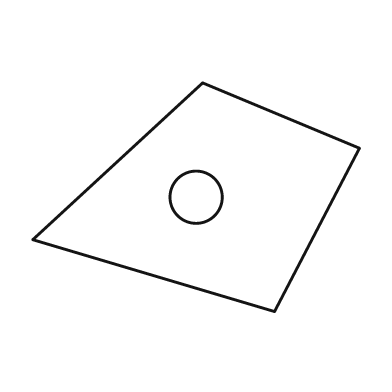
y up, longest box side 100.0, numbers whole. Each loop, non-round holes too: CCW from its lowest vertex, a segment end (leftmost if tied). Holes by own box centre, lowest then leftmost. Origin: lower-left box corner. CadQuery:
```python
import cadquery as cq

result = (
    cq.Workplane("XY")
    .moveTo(74.0, 0.0)
    .lineTo(100.0, 50.0)
    .lineTo(52.0, 70.0)
    .lineTo(0.0, 22.0)
    .close()
    .moveTo(50.0, 35.0)
    .circle(8.0)
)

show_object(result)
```